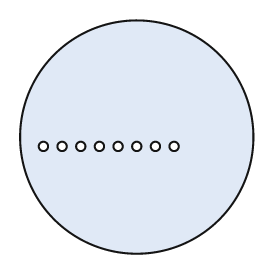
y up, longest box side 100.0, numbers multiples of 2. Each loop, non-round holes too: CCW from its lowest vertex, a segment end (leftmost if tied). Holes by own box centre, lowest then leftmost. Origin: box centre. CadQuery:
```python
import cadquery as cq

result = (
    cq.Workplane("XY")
    .moveTo(0.0, 0.0)
    .circle(50.0)
    .moveTo(-40.0, -4.0)
    .circle(2.0)
    .moveTo(-32.0, -4.0)
    .circle(2.0)
    .moveTo(-24.0, -4.0)
    .circle(2.0)
    .moveTo(-16.0, -4.0)
    .circle(2.0)
    .moveTo(-8.0, -4.0)
    .circle(2.0)
    .moveTo(0.0, -4.0)
    .circle(2.0)
    .moveTo(8.0, -4.0)
    .circle(2.0)
    .moveTo(16.0, -4.0)
    .circle(2.0)
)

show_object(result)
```